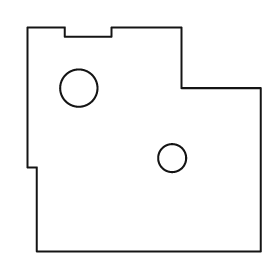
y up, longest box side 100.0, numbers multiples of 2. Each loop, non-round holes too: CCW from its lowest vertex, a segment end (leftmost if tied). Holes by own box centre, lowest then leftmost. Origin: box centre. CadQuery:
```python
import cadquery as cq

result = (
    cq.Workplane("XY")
    .moveTo(-46.0, -48.0)
    .lineTo(50.0, -48.0)
    .lineTo(50.0, 22.0)
    .lineTo(16.0, 22.0)
    .lineTo(16.0, 48.0)
    .lineTo(-14.0, 48.0)
    .lineTo(-14.0, 44.0)
    .lineTo(-34.0, 44.0)
    .lineTo(-34.0, 48.0)
    .lineTo(-50.0, 48.0)
    .lineTo(-50.0, -12.0)
    .lineTo(-46.0, -12.0)
    .close()
    .moveTo(12.0, -8.0)
    .circle(6.0)
    .moveTo(-28.0, 22.0)
    .circle(8.0)
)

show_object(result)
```